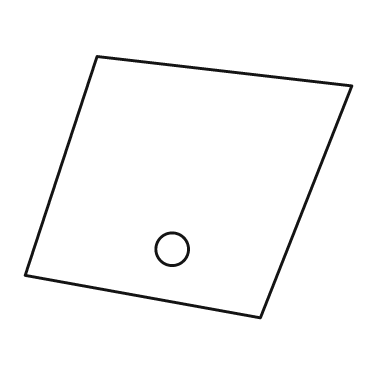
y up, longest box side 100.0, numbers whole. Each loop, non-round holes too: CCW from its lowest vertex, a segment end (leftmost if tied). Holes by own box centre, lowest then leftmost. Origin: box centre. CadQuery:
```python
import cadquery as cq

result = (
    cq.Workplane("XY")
    .moveTo(22.0, -40.0)
    .lineTo(50.0, 31.0)
    .lineTo(-28.0, 40.0)
    .lineTo(-50.0, -27.0)
    .close()
    .moveTo(-5.0, -19.0)
    .circle(5.0)
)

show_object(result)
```